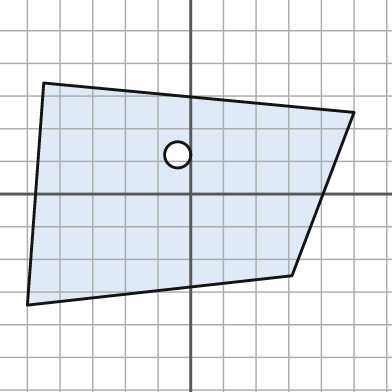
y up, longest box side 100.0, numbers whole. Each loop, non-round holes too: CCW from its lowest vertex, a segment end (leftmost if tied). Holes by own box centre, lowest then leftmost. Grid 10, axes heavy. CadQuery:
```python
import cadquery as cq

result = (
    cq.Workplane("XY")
    .moveTo(-50.0, -34.0)
    .lineTo(31.0, -25.0)
    .lineTo(50.0, 25.0)
    .lineTo(-45.0, 34.0)
    .close()
    .moveTo(-4.0, 12.0)
    .circle(4.0)
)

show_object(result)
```